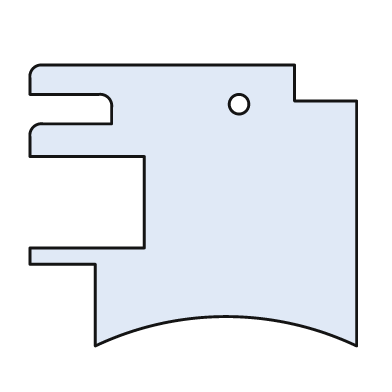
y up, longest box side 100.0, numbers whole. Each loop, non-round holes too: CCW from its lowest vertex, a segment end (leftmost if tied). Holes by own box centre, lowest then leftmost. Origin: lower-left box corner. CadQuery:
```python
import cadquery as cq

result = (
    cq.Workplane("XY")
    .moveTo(20.0, 0.0)
    .threePointArc((60.0, 9.0), (100.0, 0.0))
    .lineTo(100.0, 75.0)
    .lineTo(81.0, 75.0)
    .lineTo(81.0, 86.0)
    .lineTo(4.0, 86.0)
    .threePointArc((1.0, 85.0), (0.0, 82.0))
    .lineTo(0.0, 77.0)
    .lineTo(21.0, 77.0)
    .threePointArc((24.0, 76.0), (25.0, 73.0))
    .lineTo(25.0, 68.0)
    .lineTo(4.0, 68.0)
    .threePointArc((1.0, 67.0), (0.0, 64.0))
    .lineTo(0.0, 58.0)
    .lineTo(35.0, 58.0)
    .lineTo(35.0, 30.0)
    .lineTo(0.0, 30.0)
    .lineTo(0.0, 25.0)
    .lineTo(20.0, 25.0)
    .close()
    .moveTo(64.0, 74.0)
    .circle(3.0)
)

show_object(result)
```